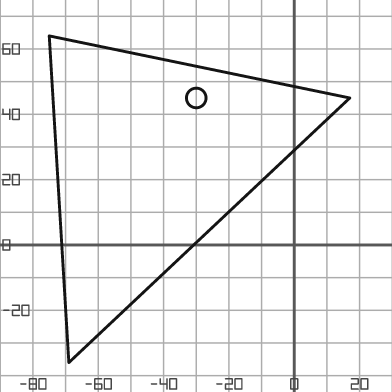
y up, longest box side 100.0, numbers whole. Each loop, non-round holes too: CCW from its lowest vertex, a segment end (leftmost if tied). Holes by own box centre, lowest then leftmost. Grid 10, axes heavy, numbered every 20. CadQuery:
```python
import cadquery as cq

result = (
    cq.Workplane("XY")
    .moveTo(-69.0, -36.0)
    .lineTo(17.0, 45.0)
    .lineTo(-75.0, 64.0)
    .close()
    .moveTo(-30.0, 45.0)
    .circle(3.0)
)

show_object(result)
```